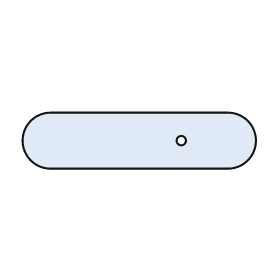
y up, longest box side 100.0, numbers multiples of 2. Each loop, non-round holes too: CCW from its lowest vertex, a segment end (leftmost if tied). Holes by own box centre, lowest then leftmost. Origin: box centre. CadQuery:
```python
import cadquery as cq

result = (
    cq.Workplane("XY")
    .moveTo(-38.0, -12.0)
    .lineTo(38.0, -12.0)
    .threePointArc((50.0, 0.0), (38.0, 12.0))
    .lineTo(-38.0, 12.0)
    .threePointArc((-50.0, 0.0), (-38.0, -12.0))
    .close()
    .moveTo(18.0, 0.0)
    .circle(2.0)
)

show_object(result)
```